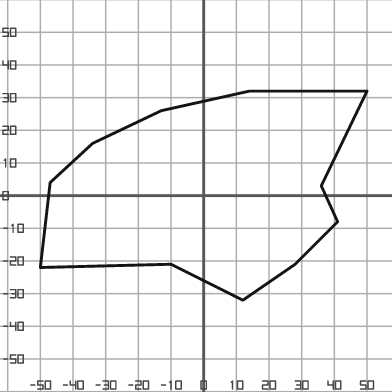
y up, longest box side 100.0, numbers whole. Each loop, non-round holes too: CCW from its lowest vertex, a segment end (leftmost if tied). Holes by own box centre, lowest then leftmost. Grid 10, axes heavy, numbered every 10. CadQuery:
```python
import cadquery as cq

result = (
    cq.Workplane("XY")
    .moveTo(12.0, -32.0)
    .lineTo(28.0, -21.0)
    .lineTo(41.0, -8.0)
    .lineTo(36.0, 3.0)
    .lineTo(50.0, 32.0)
    .lineTo(14.0, 32.0)
    .lineTo(-13.0, 26.0)
    .lineTo(-34.0, 16.0)
    .lineTo(-47.0, 4.0)
    .lineTo(-50.0, -22.0)
    .lineTo(-10.0, -21.0)
    .close()
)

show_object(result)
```